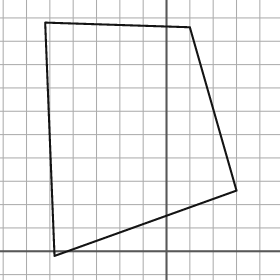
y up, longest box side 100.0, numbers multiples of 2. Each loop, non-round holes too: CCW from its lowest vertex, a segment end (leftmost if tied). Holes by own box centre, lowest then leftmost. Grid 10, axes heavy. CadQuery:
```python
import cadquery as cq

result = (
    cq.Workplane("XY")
    .moveTo(-48.0, -2.0)
    .lineTo(30.0, 26.0)
    .lineTo(10.0, 96.0)
    .lineTo(-52.0, 98.0)
    .close()
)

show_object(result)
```